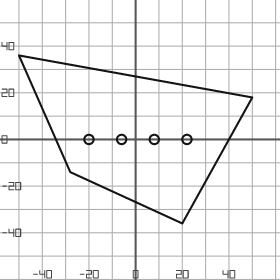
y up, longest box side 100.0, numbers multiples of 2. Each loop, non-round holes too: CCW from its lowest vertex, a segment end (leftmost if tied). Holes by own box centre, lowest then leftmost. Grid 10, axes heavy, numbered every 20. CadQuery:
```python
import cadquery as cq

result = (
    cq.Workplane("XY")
    .moveTo(20.0, -36.0)
    .lineTo(50.0, 18.0)
    .lineTo(-50.0, 36.0)
    .lineTo(-28.0, -14.0)
    .close()
    .moveTo(-20.0, 0.0)
    .circle(2.0)
    .moveTo(-6.0, 0.0)
    .circle(2.0)
    .moveTo(8.0, 0.0)
    .circle(2.0)
    .moveTo(22.0, 0.0)
    .circle(2.0)
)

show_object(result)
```